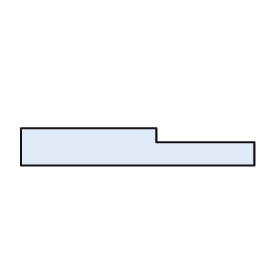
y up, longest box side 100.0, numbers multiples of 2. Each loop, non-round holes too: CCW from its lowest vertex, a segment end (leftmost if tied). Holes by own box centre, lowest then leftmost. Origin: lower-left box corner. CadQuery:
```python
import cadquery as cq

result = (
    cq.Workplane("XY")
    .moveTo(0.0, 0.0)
    .lineTo(100.0, 0.0)
    .lineTo(100.0, 10.0)
    .lineTo(58.0, 10.0)
    .lineTo(58.0, 16.0)
    .lineTo(0.0, 16.0)
    .close()
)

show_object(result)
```